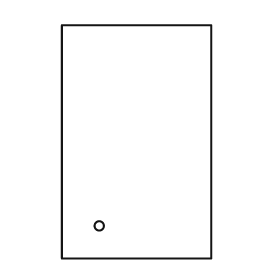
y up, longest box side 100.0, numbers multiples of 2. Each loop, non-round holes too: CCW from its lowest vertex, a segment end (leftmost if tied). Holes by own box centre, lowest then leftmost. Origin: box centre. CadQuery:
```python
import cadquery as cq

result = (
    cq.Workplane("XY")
    .moveTo(-32.0, -50.0)
    .lineTo(32.0, -50.0)
    .lineTo(32.0, 50.0)
    .lineTo(-32.0, 50.0)
    .close()
    .moveTo(-16.0, -36.0)
    .circle(2.0)
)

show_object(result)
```